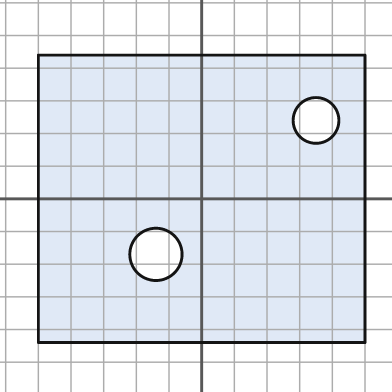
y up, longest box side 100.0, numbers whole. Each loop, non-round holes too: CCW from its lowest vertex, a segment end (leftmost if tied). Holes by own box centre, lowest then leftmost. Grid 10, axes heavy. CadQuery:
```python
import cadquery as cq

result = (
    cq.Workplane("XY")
    .moveTo(-50.0, -44.0)
    .lineTo(50.0, -44.0)
    .lineTo(50.0, 44.0)
    .lineTo(-50.0, 44.0)
    .close()
    .moveTo(-14.0, -17.0)
    .circle(8.0)
    .moveTo(35.0, 24.0)
    .circle(7.0)
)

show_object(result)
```